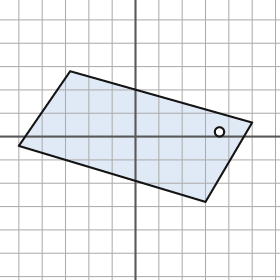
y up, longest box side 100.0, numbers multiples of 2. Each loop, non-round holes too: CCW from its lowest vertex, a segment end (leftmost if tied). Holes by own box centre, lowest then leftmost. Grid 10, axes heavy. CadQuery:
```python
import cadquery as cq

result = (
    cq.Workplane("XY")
    .moveTo(30.0, -28.0)
    .lineTo(50.0, 6.0)
    .lineTo(-28.0, 28.0)
    .lineTo(-50.0, -4.0)
    .close()
    .moveTo(36.0, 2.0)
    .circle(2.0)
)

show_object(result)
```